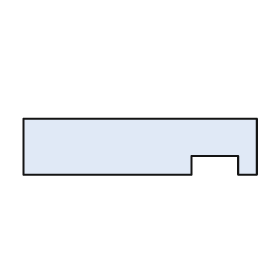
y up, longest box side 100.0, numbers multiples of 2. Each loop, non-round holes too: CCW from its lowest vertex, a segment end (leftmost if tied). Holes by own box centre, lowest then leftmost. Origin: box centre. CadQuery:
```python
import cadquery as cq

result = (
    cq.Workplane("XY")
    .moveTo(-50.0, -12.0)
    .lineTo(22.0, -12.0)
    .lineTo(22.0, -4.0)
    .lineTo(42.0, -4.0)
    .lineTo(42.0, -12.0)
    .lineTo(50.0, -12.0)
    .lineTo(50.0, 12.0)
    .lineTo(-50.0, 12.0)
    .close()
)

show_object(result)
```